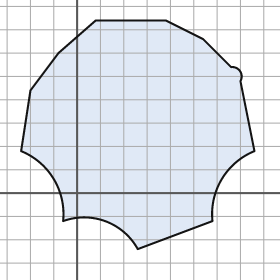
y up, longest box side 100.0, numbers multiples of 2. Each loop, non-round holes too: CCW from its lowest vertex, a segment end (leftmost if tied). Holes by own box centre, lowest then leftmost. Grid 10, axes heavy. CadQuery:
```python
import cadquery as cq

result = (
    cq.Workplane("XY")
    .moveTo(26.0, -24.0)
    .lineTo(58.0, -12.0)
    .threePointArc((62.0, 6.0), (76.0, 18.0))
    .lineTo(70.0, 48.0)
    .threePointArc((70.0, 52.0), (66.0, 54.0))
    .lineTo(54.0, 66.0)
    .lineTo(38.0, 74.0)
    .lineTo(8.0, 74.0)
    .lineTo(-8.0, 60.0)
    .lineTo(-20.0, 44.0)
    .lineTo(-24.0, 18.0)
    .threePointArc((-10.0, 6.0), (-6.0, -12.0))
    .threePointArc((12.0, -12.0), (26.0, -24.0))
    .close()
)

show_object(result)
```